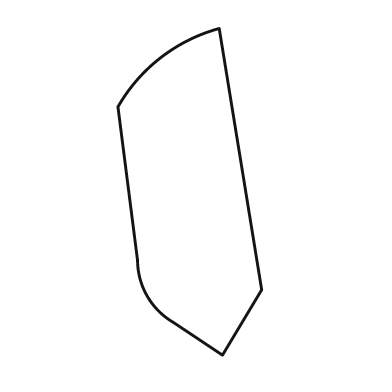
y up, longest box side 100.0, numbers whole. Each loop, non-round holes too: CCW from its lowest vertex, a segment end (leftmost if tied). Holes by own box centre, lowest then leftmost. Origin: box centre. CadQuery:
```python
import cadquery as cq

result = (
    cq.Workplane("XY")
    .moveTo(10.0, -50.0)
    .lineTo(22.0, -30.0)
    .lineTo(9.0, 50.0)
    .threePointArc((-9.0, 41.0), (-22.0, 26.0))
    .lineTo(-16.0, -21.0)
    .threePointArc((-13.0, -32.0), (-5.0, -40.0))
    .close()
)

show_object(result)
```